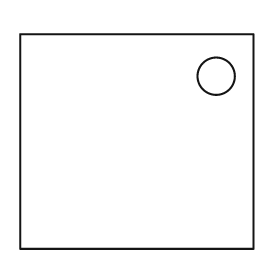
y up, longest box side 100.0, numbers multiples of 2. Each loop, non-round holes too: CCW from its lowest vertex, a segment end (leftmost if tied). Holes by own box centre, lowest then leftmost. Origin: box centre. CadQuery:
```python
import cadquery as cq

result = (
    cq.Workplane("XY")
    .moveTo(-50.0, -46.0)
    .lineTo(50.0, -46.0)
    .lineTo(50.0, 46.0)
    .lineTo(-50.0, 46.0)
    .close()
    .moveTo(34.0, 28.0)
    .circle(8.0)
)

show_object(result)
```